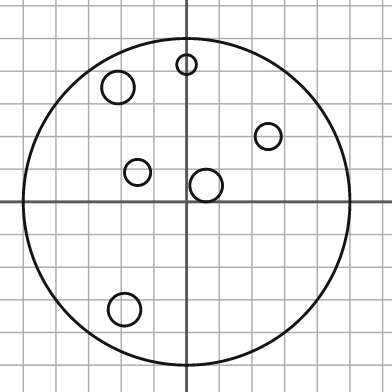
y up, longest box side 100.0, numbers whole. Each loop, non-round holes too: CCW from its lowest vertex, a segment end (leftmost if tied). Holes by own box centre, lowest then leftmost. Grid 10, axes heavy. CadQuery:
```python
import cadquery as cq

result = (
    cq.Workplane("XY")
    .moveTo(0.0, 0.0)
    .circle(50.0)
    .moveTo(-19.0, -33.0)
    .circle(5.0)
    .moveTo(6.0, 5.0)
    .circle(5.0)
    .moveTo(-15.0, 9.0)
    .circle(4.0)
    .moveTo(25.0, 20.0)
    .circle(4.0)
    .moveTo(-21.0, 35.0)
    .circle(5.0)
    .moveTo(0.0, 42.0)
    .circle(3.0)
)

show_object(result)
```